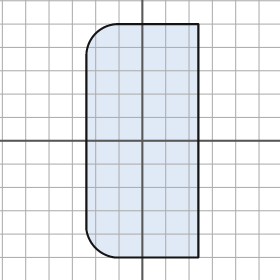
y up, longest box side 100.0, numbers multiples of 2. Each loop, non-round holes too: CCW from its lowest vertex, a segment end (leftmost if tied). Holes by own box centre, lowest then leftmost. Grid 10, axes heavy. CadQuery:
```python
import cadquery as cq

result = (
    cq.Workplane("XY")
    .moveTo(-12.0, -50.0)
    .lineTo(24.0, -50.0)
    .lineTo(24.0, 50.0)
    .lineTo(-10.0, 50.0)
    .threePointArc((-20.0, 46.0), (-24.0, 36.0))
    .lineTo(-24.0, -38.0)
    .threePointArc((-20.0, -46.0), (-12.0, -50.0))
    .close()
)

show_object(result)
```